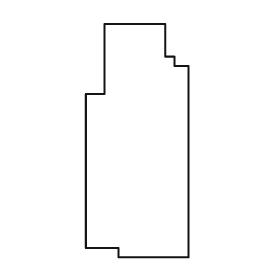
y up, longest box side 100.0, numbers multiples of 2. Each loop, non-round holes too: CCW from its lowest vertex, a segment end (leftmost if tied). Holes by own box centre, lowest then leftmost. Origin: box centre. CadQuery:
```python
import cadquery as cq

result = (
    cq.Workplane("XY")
    .moveTo(-8.0, -50.0)
    .lineTo(22.0, -50.0)
    .lineTo(22.0, 32.0)
    .lineTo(16.0, 32.0)
    .lineTo(16.0, 36.0)
    .lineTo(12.0, 36.0)
    .lineTo(12.0, 50.0)
    .lineTo(-14.0, 50.0)
    .lineTo(-14.0, 20.0)
    .lineTo(-22.0, 20.0)
    .lineTo(-22.0, -46.0)
    .lineTo(-8.0, -46.0)
    .close()
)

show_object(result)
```